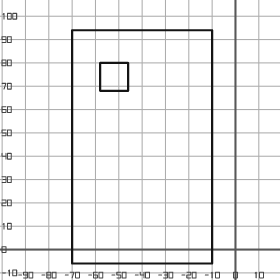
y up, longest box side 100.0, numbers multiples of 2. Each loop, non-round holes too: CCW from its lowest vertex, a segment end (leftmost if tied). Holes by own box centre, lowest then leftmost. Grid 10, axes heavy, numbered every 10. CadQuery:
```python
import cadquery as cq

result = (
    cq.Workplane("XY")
    .moveTo(-70.0, -6.0)
    .lineTo(-10.0, -6.0)
    .lineTo(-10.0, 94.0)
    .lineTo(-70.0, 94.0)
    .close()
    .moveTo(-58.0, 68.0)
    .lineTo(-46.0, 68.0)
    .lineTo(-46.0, 80.0)
    .lineTo(-58.0, 80.0)
    .close()
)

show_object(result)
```